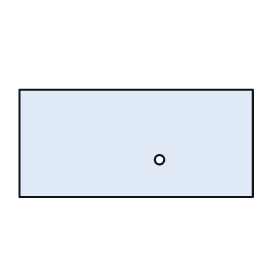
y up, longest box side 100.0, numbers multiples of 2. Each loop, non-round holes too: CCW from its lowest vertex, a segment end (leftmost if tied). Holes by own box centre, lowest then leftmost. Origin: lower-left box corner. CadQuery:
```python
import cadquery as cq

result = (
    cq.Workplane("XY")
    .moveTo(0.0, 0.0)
    .lineTo(100.0, 0.0)
    .lineTo(100.0, 46.0)
    .lineTo(0.0, 46.0)
    .close()
    .moveTo(60.0, 16.0)
    .circle(2.0)
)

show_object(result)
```